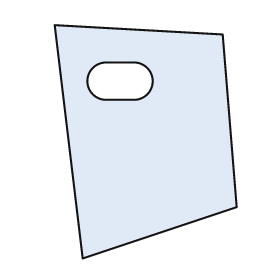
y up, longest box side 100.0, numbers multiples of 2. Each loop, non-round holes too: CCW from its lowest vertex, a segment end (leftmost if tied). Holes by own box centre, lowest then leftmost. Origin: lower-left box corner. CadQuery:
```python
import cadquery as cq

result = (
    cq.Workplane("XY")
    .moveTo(12.0, 0.0)
    .lineTo(78.0, 22.0)
    .lineTo(72.0, 96.0)
    .lineTo(0.0, 100.0)
    .close()
    .moveTo(22.0, 68.0)
    .lineTo(34.0, 68.0)
    .threePointArc((42.0, 76.0), (34.0, 84.0))
    .lineTo(22.0, 84.0)
    .threePointArc((14.0, 76.0), (22.0, 68.0))
    .close()
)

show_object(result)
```